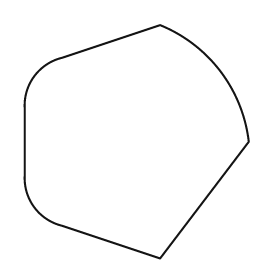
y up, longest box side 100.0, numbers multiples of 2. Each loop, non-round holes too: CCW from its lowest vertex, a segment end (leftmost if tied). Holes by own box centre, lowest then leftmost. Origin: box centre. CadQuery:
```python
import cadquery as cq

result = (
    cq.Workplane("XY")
    .moveTo(10.0, -50.0)
    .lineTo(48.0, 0.0)
    .threePointArc((36.0, 30.0), (10.0, 50.0))
    .lineTo(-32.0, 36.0)
    .threePointArc((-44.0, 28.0), (-48.0, 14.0))
    .lineTo(-48.0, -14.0)
    .threePointArc((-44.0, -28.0), (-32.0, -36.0))
    .close()
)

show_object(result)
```